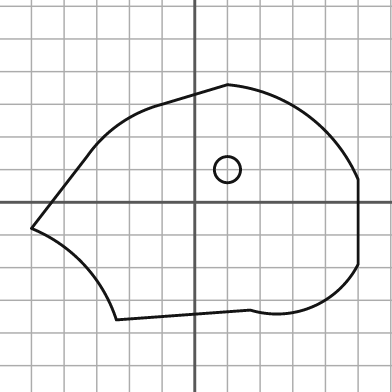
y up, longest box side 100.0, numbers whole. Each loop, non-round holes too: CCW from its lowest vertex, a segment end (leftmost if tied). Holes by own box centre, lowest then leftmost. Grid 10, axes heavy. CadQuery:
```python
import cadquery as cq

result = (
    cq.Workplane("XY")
    .moveTo(-24.0, -36.0)
    .lineTo(17.0, -33.0)
    .threePointArc((36.0, -32.0), (50.0, -19.0))
    .lineTo(50.0, 7.0)
    .threePointArc((34.0, 27.0), (10.0, 36.0))
    .lineTo(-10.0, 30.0)
    .threePointArc((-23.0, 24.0), (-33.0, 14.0))
    .lineTo(-50.0, -8.0)
    .threePointArc((-34.0, -19.0), (-24.0, -36.0))
    .close()
    .moveTo(10.0, 10.0)
    .circle(4.0)
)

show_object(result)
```